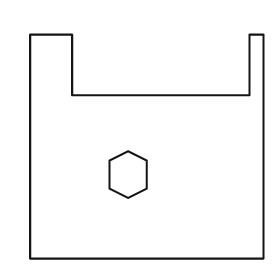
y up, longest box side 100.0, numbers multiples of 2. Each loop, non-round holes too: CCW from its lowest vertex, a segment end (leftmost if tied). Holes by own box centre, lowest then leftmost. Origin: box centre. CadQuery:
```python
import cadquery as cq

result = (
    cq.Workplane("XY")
    .moveTo(-50.0, -48.0)
    .lineTo(50.0, -48.0)
    .lineTo(50.0, 48.0)
    .lineTo(44.0, 48.0)
    .lineTo(44.0, 22.0)
    .lineTo(-32.0, 22.0)
    .lineTo(-32.0, 48.0)
    .lineTo(-50.0, 48.0)
    .close()
    .moveTo(-8.0, -22.0)
    .lineTo(0.0, -18.0)
    .lineTo(0.0, -6.0)
    .lineTo(-8.0, -2.0)
    .lineTo(-16.0, -6.0)
    .lineTo(-16.0, -18.0)
    .close()
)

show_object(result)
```